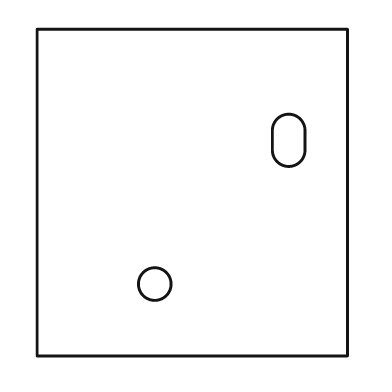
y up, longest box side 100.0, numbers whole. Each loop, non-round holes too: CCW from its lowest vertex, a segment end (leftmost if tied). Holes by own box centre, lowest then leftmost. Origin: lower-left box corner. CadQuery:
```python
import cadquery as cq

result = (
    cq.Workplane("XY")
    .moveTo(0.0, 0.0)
    .lineTo(95.0, 0.0)
    .lineTo(95.0, 100.0)
    .lineTo(0.0, 100.0)
    .close()
    .moveTo(36.0, 22.0)
    .circle(5.0)
    .moveTo(72.0, 63.0)
    .threePointArc((77.0, 58.0), (82.0, 63.0))
    .lineTo(82.0, 69.0)
    .threePointArc((77.0, 74.0), (72.0, 69.0))
    .close()
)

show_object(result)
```